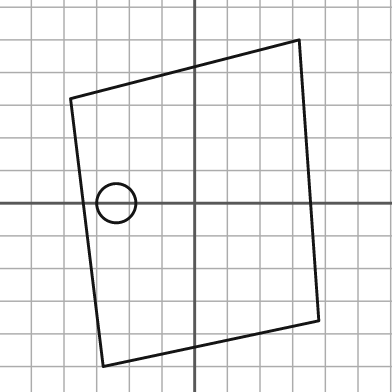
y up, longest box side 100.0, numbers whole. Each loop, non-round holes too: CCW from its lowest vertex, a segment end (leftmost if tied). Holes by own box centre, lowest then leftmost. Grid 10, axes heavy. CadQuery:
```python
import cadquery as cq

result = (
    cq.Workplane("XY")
    .moveTo(-28.0, -50.0)
    .lineTo(38.0, -36.0)
    .lineTo(32.0, 50.0)
    .lineTo(-38.0, 32.0)
    .close()
    .moveTo(-24.0, 0.0)
    .circle(6.0)
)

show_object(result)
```